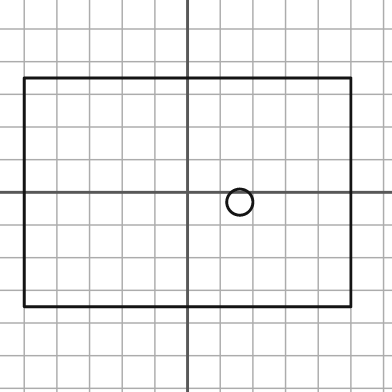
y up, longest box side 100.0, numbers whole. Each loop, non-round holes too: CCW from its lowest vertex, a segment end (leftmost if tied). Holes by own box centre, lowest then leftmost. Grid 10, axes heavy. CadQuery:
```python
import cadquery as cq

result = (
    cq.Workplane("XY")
    .moveTo(-50.0, -35.0)
    .lineTo(50.0, -35.0)
    .lineTo(50.0, 35.0)
    .lineTo(-50.0, 35.0)
    .close()
    .moveTo(16.0, -3.0)
    .circle(4.0)
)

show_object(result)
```